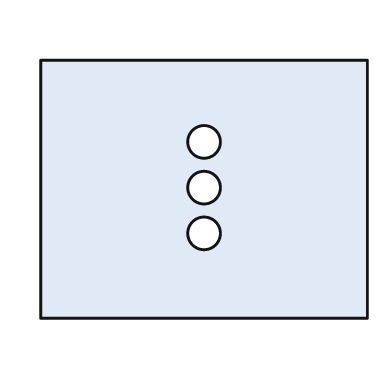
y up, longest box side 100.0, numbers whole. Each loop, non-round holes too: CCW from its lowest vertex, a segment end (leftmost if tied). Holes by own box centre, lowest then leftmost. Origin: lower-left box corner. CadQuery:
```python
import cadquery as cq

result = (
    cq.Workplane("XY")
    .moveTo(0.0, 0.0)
    .lineTo(100.0, 0.0)
    .lineTo(100.0, 79.0)
    .lineTo(0.0, 79.0)
    .close()
    .moveTo(50.0, 26.0)
    .circle(5.0)
    .moveTo(50.0, 40.0)
    .circle(5.0)
    .moveTo(50.0, 54.0)
    .circle(5.0)
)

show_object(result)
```